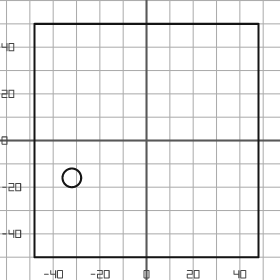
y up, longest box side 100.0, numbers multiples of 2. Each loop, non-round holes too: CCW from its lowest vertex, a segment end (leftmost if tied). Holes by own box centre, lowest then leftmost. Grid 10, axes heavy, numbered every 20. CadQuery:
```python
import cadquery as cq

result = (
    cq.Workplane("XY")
    .moveTo(-48.0, -50.0)
    .lineTo(48.0, -50.0)
    .lineTo(48.0, 50.0)
    .lineTo(-48.0, 50.0)
    .close()
    .moveTo(-32.0, -16.0)
    .circle(4.0)
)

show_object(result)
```